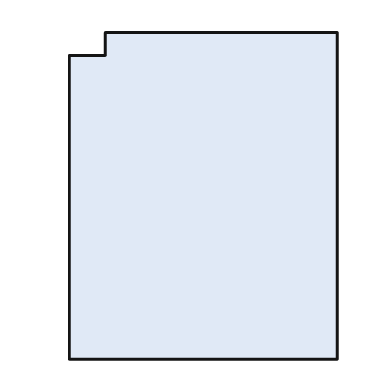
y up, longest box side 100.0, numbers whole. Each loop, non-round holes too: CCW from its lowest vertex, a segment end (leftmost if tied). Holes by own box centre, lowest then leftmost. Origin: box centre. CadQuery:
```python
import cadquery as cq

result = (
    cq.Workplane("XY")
    .moveTo(-41.0, -50.0)
    .lineTo(41.0, -50.0)
    .lineTo(41.0, 50.0)
    .lineTo(-30.0, 50.0)
    .lineTo(-30.0, 43.0)
    .lineTo(-41.0, 43.0)
    .close()
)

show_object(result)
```